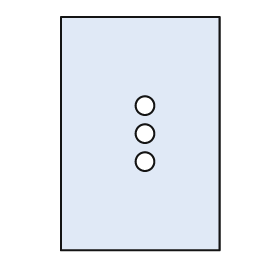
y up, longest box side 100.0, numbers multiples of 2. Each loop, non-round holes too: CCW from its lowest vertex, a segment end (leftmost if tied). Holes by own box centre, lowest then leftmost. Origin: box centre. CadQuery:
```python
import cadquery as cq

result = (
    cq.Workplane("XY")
    .moveTo(-34.0, -50.0)
    .lineTo(34.0, -50.0)
    .lineTo(34.0, 50.0)
    .lineTo(-34.0, 50.0)
    .close()
    .moveTo(2.0, -12.0)
    .circle(4.0)
    .moveTo(2.0, 0.0)
    .circle(4.0)
    .moveTo(2.0, 12.0)
    .circle(4.0)
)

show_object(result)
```